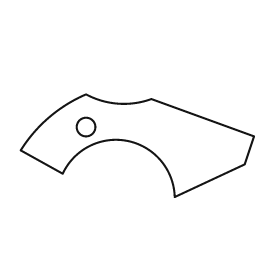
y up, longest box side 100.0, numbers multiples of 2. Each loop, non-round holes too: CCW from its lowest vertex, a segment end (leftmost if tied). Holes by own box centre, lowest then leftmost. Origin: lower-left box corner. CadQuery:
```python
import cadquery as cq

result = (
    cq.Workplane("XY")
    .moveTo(66.0, 0.0)
    .lineTo(96.0, 14.0)
    .lineTo(100.0, 26.0)
    .lineTo(56.0, 42.0)
    .threePointArc((42.0, 40.0), (28.0, 44.0))
    .threePointArc((12.0, 34.0), (0.0, 20.0))
    .lineTo(18.0, 10.0)
    .threePointArc((46.0, 24.0), (66.0, 0.0))
    .close()
    .moveTo(28.0, 30.0)
    .circle(4.0)
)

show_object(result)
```